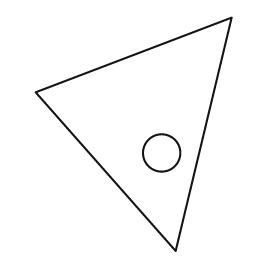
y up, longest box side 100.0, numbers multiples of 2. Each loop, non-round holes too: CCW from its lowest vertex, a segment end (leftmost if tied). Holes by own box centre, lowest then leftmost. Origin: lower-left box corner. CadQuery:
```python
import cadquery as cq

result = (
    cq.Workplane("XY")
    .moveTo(60.0, 0.0)
    .lineTo(84.0, 100.0)
    .lineTo(0.0, 68.0)
    .close()
    .moveTo(54.0, 42.0)
    .circle(8.0)
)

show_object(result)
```